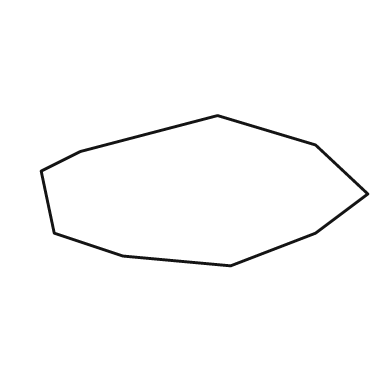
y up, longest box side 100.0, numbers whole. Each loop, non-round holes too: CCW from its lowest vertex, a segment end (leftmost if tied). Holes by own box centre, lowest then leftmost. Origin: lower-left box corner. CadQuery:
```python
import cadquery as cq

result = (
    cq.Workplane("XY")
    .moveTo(58.0, 0.0)
    .lineTo(84.0, 10.0)
    .lineTo(100.0, 22.0)
    .lineTo(84.0, 37.0)
    .lineTo(54.0, 46.0)
    .lineTo(12.0, 35.0)
    .lineTo(0.0, 29.0)
    .lineTo(4.0, 10.0)
    .lineTo(25.0, 3.0)
    .close()
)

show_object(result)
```